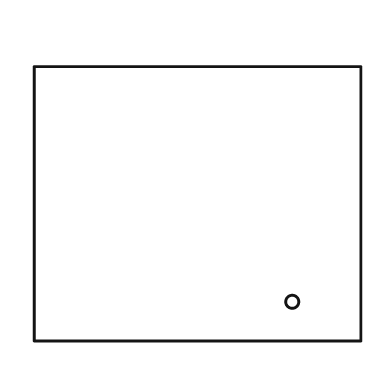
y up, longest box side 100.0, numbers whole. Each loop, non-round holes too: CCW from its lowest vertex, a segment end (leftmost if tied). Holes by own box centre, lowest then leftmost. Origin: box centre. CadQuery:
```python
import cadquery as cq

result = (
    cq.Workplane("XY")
    .moveTo(-50.0, -42.0)
    .lineTo(50.0, -42.0)
    .lineTo(50.0, 42.0)
    .lineTo(-50.0, 42.0)
    .close()
    .moveTo(29.0, -30.0)
    .circle(2.0)
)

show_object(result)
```